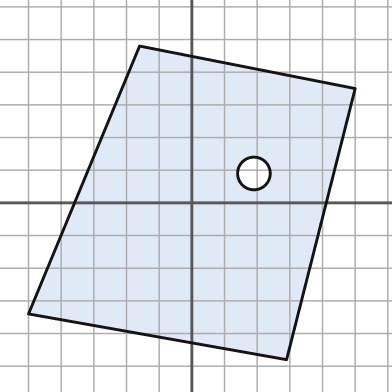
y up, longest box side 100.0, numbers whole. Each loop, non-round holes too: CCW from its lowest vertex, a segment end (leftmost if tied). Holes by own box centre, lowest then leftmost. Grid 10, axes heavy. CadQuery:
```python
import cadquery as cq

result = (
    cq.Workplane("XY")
    .moveTo(29.0, -48.0)
    .lineTo(50.0, 35.0)
    .lineTo(-16.0, 48.0)
    .lineTo(-50.0, -34.0)
    .close()
    .moveTo(19.0, 9.0)
    .circle(5.0)
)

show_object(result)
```